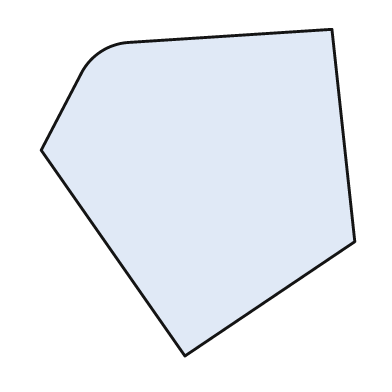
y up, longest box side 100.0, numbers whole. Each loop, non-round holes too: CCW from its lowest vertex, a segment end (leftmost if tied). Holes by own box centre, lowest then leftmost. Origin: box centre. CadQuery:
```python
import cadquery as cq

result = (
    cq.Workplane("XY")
    .moveTo(-4.0, -50.0)
    .lineTo(48.0, -15.0)
    .lineTo(41.0, 50.0)
    .lineTo(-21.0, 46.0)
    .threePointArc((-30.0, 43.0), (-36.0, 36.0))
    .lineTo(-48.0, 13.0)
    .close()
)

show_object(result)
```